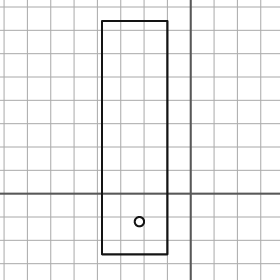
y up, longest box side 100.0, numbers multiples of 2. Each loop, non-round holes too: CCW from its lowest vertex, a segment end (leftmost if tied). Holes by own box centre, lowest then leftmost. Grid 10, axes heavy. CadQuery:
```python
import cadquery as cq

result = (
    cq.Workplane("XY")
    .moveTo(-38.0, -26.0)
    .lineTo(-10.0, -26.0)
    .lineTo(-10.0, 74.0)
    .lineTo(-38.0, 74.0)
    .close()
    .moveTo(-22.0, -12.0)
    .circle(2.0)
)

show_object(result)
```